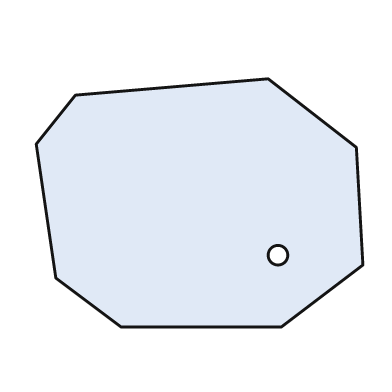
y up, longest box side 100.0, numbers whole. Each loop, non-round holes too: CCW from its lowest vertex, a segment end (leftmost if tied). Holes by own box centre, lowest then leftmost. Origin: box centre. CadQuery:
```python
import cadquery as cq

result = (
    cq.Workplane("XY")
    .moveTo(-24.0, -38.0)
    .lineTo(25.0, -38.0)
    .lineTo(50.0, -19.0)
    .lineTo(48.0, 17.0)
    .lineTo(21.0, 38.0)
    .lineTo(-38.0, 33.0)
    .lineTo(-50.0, 18.0)
    .lineTo(-44.0, -23.0)
    .close()
    .moveTo(24.0, -16.0)
    .circle(3.0)
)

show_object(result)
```